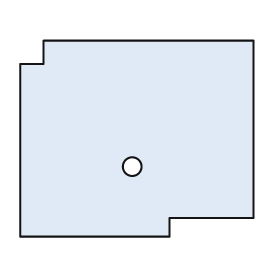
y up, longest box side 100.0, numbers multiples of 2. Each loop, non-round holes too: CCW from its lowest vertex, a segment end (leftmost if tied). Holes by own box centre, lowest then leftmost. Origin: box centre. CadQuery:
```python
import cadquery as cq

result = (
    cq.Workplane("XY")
    .moveTo(-50.0, -42.0)
    .lineTo(14.0, -42.0)
    .lineTo(14.0, -34.0)
    .lineTo(50.0, -34.0)
    .lineTo(50.0, 42.0)
    .lineTo(-40.0, 42.0)
    .lineTo(-40.0, 32.0)
    .lineTo(-50.0, 32.0)
    .close()
    .moveTo(-2.0, -12.0)
    .circle(4.0)
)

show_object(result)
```